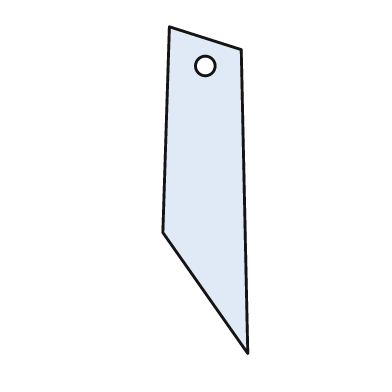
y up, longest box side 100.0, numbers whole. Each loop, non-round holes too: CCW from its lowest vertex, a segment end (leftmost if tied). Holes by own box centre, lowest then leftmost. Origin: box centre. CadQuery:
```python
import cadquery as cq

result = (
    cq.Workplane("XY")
    .moveTo(13.0, -50.0)
    .lineTo(11.0, 43.0)
    .lineTo(-11.0, 50.0)
    .lineTo(-13.0, -13.0)
    .close()
    .moveTo(0.0, 38.0)
    .circle(3.0)
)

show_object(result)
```